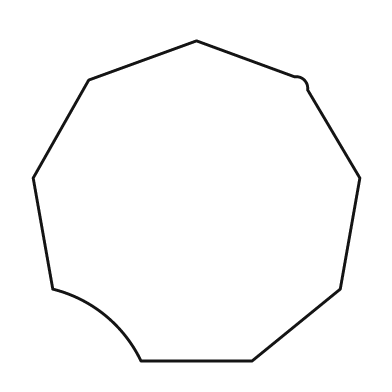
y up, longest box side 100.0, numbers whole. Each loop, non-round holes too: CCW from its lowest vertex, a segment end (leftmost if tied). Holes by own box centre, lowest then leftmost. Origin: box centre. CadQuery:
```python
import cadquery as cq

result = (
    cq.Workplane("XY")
    .moveTo(-17.0, -49.0)
    .lineTo(17.0, -49.0)
    .lineTo(44.0, -27.0)
    .lineTo(50.0, 7.0)
    .lineTo(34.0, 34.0)
    .threePointArc((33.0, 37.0), (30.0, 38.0))
    .lineTo(0.0, 49.0)
    .lineTo(-33.0, 37.0)
    .lineTo(-50.0, 7.0)
    .lineTo(-44.0, -27.0)
    .threePointArc((-28.0, -35.0), (-17.0, -49.0))
    .close()
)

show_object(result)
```